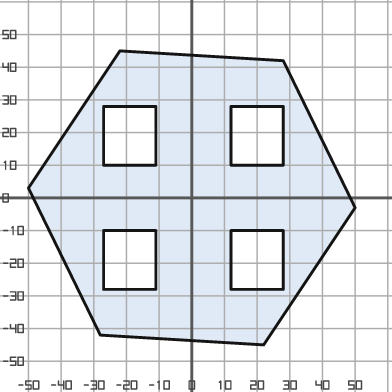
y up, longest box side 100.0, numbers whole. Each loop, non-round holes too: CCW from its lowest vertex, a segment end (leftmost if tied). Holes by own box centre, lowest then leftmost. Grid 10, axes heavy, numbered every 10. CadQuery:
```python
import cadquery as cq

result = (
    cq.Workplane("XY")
    .moveTo(22.0, -45.0)
    .lineTo(50.0, -3.0)
    .lineTo(28.0, 42.0)
    .lineTo(-22.0, 45.0)
    .lineTo(-50.0, 3.0)
    .lineTo(-28.0, -42.0)
    .close()
    .moveTo(-27.0, -28.0)
    .lineTo(-11.0, -28.0)
    .lineTo(-11.0, -10.0)
    .lineTo(-27.0, -10.0)
    .close()
    .moveTo(12.0, -28.0)
    .lineTo(28.0, -28.0)
    .lineTo(28.0, -10.0)
    .lineTo(12.0, -10.0)
    .close()
    .moveTo(-27.0, 10.0)
    .lineTo(-11.0, 10.0)
    .lineTo(-11.0, 28.0)
    .lineTo(-27.0, 28.0)
    .close()
    .moveTo(12.0, 10.0)
    .lineTo(28.0, 10.0)
    .lineTo(28.0, 28.0)
    .lineTo(12.0, 28.0)
    .close()
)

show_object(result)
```